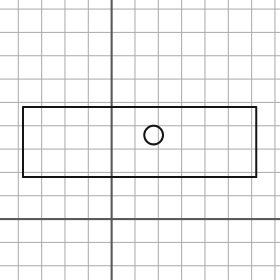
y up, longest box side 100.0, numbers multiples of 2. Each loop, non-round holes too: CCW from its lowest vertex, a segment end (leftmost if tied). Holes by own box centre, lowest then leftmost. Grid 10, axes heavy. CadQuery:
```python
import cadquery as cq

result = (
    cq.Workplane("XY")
    .moveTo(-38.0, 18.0)
    .lineTo(62.0, 18.0)
    .lineTo(62.0, 48.0)
    .lineTo(-38.0, 48.0)
    .close()
    .moveTo(18.0, 36.0)
    .circle(4.0)
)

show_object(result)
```